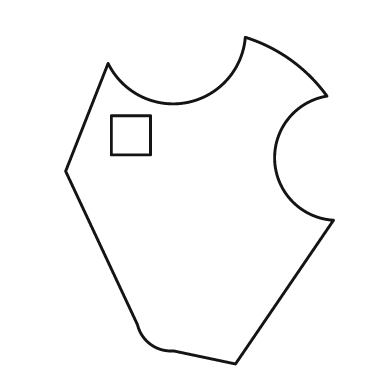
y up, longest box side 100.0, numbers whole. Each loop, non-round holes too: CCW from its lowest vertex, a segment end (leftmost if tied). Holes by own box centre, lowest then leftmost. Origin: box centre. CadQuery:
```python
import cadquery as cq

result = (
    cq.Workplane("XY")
    .moveTo(11.0, -50.0)
    .lineTo(41.0, -6.0)
    .threePointArc((23.0, 12.0), (39.0, 32.0))
    .threePointArc((28.0, 43.0), (14.0, 50.0))
    .threePointArc((-4.0, 30.0), (-28.0, 42.0))
    .lineTo(-41.0, 9.0)
    .lineTo(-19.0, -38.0)
    .threePointArc((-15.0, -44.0), (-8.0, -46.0))
    .close()
    .moveTo(-27.0, 14.0)
    .lineTo(-15.0, 14.0)
    .lineTo(-15.0, 26.0)
    .lineTo(-27.0, 26.0)
    .close()
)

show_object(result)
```